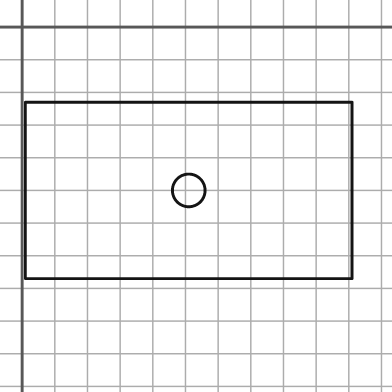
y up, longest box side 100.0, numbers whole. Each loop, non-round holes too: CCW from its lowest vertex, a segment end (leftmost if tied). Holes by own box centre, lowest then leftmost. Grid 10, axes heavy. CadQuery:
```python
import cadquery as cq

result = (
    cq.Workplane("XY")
    .moveTo(1.0, -77.0)
    .lineTo(101.0, -77.0)
    .lineTo(101.0, -23.0)
    .lineTo(1.0, -23.0)
    .close()
    .moveTo(51.0, -50.0)
    .circle(5.0)
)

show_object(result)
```